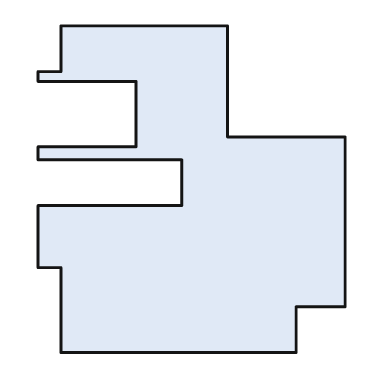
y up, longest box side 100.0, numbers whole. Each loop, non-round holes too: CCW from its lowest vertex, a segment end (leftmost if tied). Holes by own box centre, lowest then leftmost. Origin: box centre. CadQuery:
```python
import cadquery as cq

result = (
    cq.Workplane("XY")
    .moveTo(-40.0, -50.0)
    .lineTo(32.0, -50.0)
    .lineTo(32.0, -36.0)
    .lineTo(47.0, -36.0)
    .lineTo(47.0, 16.0)
    .lineTo(11.0, 16.0)
    .lineTo(11.0, 50.0)
    .lineTo(-40.0, 50.0)
    .lineTo(-40.0, 36.0)
    .lineTo(-47.0, 36.0)
    .lineTo(-47.0, 33.0)
    .lineTo(-17.0, 33.0)
    .lineTo(-17.0, 13.0)
    .lineTo(-47.0, 13.0)
    .lineTo(-47.0, 9.0)
    .lineTo(-3.0, 9.0)
    .lineTo(-3.0, -5.0)
    .lineTo(-47.0, -5.0)
    .lineTo(-47.0, -24.0)
    .lineTo(-40.0, -24.0)
    .close()
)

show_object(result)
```